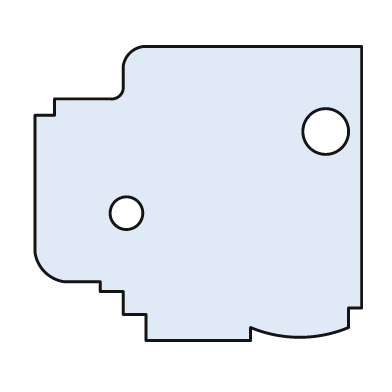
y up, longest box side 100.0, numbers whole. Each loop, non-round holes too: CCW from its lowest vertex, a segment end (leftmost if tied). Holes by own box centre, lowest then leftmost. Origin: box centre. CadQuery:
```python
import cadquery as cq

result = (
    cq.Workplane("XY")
    .moveTo(-16.0, -45.0)
    .lineTo(16.0, -45.0)
    .lineTo(16.0, -41.0)
    .threePointArc((31.0, -44.0), (46.0, -41.0))
    .lineTo(46.0, -35.0)
    .lineTo(50.0, -35.0)
    .lineTo(50.0, 45.0)
    .lineTo(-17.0, 45.0)
    .threePointArc((-21.0, 43.0), (-23.0, 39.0))
    .lineTo(-23.0, 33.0)
    .threePointArc((-24.0, 30.0), (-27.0, 29.0))
    .lineTo(-44.0, 29.0)
    .lineTo(-44.0, 24.0)
    .lineTo(-50.0, 24.0)
    .lineTo(-50.0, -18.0)
    .threePointArc((-47.0, -24.0), (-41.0, -27.0))
    .lineTo(-30.0, -27.0)
    .lineTo(-30.0, -30.0)
    .lineTo(-23.0, -30.0)
    .lineTo(-23.0, -37.0)
    .lineTo(-16.0, -37.0)
    .close()
    .moveTo(-22.0, -6.0)
    .circle(5.0)
    .moveTo(39.0, 19.0)
    .circle(7.0)
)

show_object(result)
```